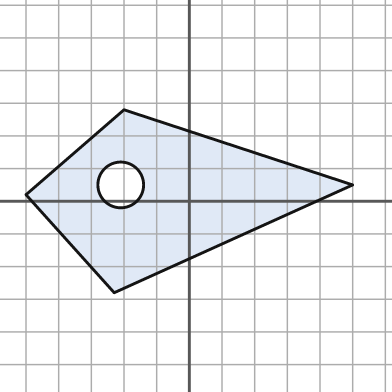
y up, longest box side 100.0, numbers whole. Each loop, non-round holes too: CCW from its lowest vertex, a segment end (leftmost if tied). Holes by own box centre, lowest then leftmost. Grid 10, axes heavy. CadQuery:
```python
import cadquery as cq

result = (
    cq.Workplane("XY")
    .moveTo(-23.0, -28.0)
    .lineTo(50.0, 5.0)
    .lineTo(-20.0, 28.0)
    .lineTo(-50.0, 2.0)
    .close()
    .moveTo(-21.0, 5.0)
    .circle(7.0)
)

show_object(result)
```